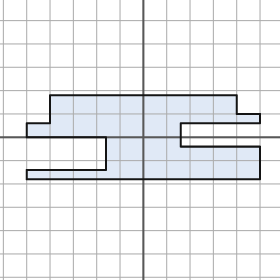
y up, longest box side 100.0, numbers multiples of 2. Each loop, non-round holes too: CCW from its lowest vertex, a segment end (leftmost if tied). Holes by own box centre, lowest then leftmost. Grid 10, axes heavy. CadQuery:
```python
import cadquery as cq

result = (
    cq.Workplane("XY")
    .moveTo(-50.0, -18.0)
    .lineTo(50.0, -18.0)
    .lineTo(50.0, -4.0)
    .lineTo(16.0, -4.0)
    .lineTo(16.0, 6.0)
    .lineTo(50.0, 6.0)
    .lineTo(50.0, 10.0)
    .lineTo(40.0, 10.0)
    .lineTo(40.0, 18.0)
    .lineTo(-40.0, 18.0)
    .lineTo(-40.0, 6.0)
    .lineTo(-50.0, 6.0)
    .lineTo(-50.0, 0.0)
    .lineTo(-16.0, 0.0)
    .lineTo(-16.0, -14.0)
    .lineTo(-50.0, -14.0)
    .close()
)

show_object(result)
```